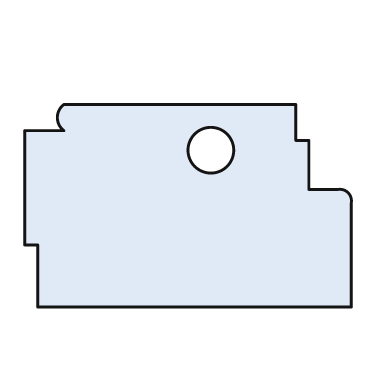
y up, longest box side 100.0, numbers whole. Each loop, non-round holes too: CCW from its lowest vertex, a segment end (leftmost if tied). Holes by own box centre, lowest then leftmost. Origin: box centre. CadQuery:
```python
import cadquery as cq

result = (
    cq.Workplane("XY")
    .moveTo(-46.0, -31.0)
    .lineTo(50.0, -31.0)
    .lineTo(50.0, 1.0)
    .threePointArc((49.0, 4.0), (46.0, 5.0))
    .lineTo(37.0, 5.0)
    .lineTo(37.0, 20.0)
    .lineTo(33.0, 20.0)
    .lineTo(33.0, 31.0)
    .lineTo(-38.0, 31.0)
    .threePointArc((-40.0, 27.0), (-38.0, 23.0))
    .lineTo(-50.0, 23.0)
    .lineTo(-50.0, -12.0)
    .lineTo(-46.0, -12.0)
    .close()
    .moveTo(7.0, 17.0)
    .circle(7.0)
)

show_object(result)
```